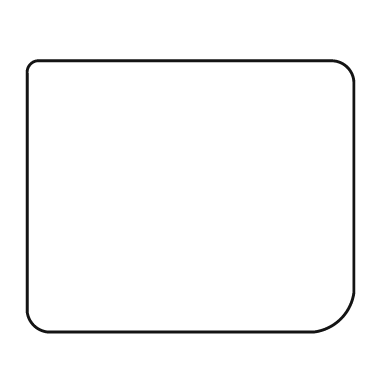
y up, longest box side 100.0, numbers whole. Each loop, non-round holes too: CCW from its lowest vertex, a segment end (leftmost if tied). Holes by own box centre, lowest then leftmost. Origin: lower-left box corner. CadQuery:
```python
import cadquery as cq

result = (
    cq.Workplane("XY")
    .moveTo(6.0, 0.0)
    .lineTo(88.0, 0.0)
    .threePointArc((96.0, 4.0), (100.0, 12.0))
    .lineTo(100.0, 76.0)
    .threePointArc((98.0, 81.0), (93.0, 83.0))
    .lineTo(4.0, 83.0)
    .threePointArc((1.0, 82.0), (0.0, 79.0))
    .lineTo(0.0, 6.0)
    .threePointArc((2.0, 2.0), (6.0, 0.0))
    .close()
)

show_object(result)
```